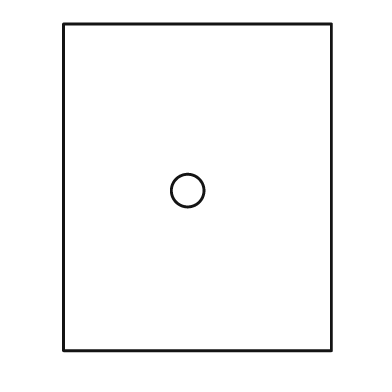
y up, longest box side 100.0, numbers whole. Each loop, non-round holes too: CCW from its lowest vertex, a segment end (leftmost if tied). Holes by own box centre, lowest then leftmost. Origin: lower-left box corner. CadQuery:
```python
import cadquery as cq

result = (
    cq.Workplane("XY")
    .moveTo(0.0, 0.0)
    .lineTo(82.0, 0.0)
    .lineTo(82.0, 100.0)
    .lineTo(0.0, 100.0)
    .close()
    .moveTo(38.0, 49.0)
    .circle(5.0)
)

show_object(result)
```